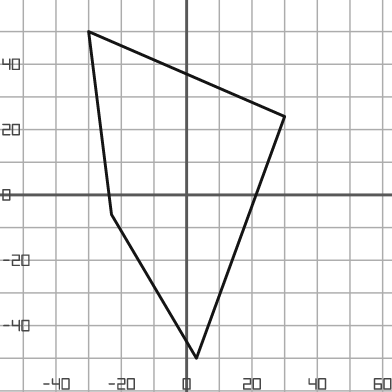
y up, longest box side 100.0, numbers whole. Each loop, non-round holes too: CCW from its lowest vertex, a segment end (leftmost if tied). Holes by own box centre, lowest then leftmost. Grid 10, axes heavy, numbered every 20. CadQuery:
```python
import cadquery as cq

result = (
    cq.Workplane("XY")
    .moveTo(3.0, -50.0)
    .lineTo(30.0, 24.0)
    .lineTo(-30.0, 50.0)
    .lineTo(-23.0, -6.0)
    .close()
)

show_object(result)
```